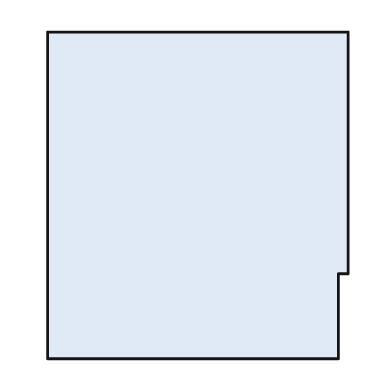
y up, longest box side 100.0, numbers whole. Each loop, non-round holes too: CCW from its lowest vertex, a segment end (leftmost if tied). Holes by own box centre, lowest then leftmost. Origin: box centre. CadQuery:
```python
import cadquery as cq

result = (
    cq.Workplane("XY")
    .moveTo(-46.0, -50.0)
    .lineTo(43.0, -50.0)
    .lineTo(43.0, -24.0)
    .lineTo(46.0, -24.0)
    .lineTo(46.0, 50.0)
    .lineTo(-46.0, 50.0)
    .close()
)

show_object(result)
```